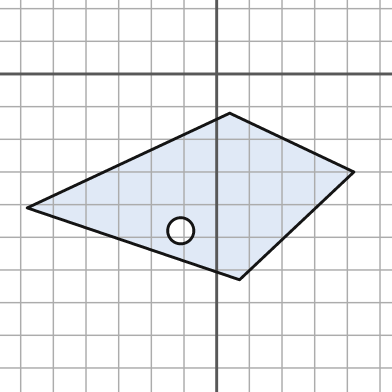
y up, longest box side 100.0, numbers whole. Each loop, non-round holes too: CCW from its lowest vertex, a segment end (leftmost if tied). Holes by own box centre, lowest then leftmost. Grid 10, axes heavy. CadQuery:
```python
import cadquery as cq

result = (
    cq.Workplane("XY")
    .moveTo(7.0, -63.0)
    .lineTo(42.0, -30.0)
    .lineTo(4.0, -12.0)
    .lineTo(-58.0, -41.0)
    .close()
    .moveTo(-11.0, -48.0)
    .circle(4.0)
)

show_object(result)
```